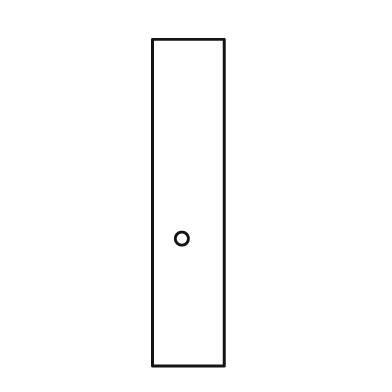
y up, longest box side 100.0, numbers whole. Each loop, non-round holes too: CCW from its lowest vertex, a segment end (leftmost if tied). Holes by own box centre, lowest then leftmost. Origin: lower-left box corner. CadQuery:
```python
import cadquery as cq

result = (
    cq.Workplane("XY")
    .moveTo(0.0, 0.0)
    .lineTo(22.0, 0.0)
    .lineTo(22.0, 100.0)
    .lineTo(0.0, 100.0)
    .close()
    .moveTo(9.0, 39.0)
    .circle(2.0)
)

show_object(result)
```